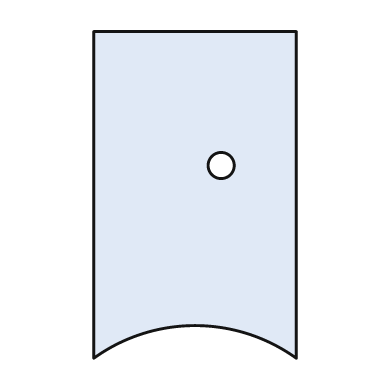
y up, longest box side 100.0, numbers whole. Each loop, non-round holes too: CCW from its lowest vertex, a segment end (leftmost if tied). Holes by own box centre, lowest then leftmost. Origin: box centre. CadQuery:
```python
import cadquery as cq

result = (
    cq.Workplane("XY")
    .moveTo(-31.0, -50.0)
    .threePointArc((0.0, -40.0), (31.0, -50.0))
    .lineTo(31.0, 50.0)
    .lineTo(-31.0, 50.0)
    .close()
    .moveTo(8.0, 9.0)
    .circle(4.0)
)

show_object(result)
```